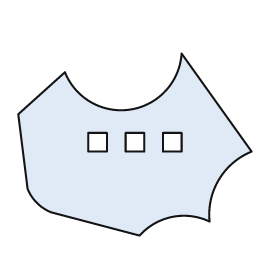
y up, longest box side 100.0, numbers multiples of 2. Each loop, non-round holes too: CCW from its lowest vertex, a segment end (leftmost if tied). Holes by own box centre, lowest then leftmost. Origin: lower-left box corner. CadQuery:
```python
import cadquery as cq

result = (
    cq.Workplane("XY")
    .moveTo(52.0, 0.0)
    .threePointArc((66.0, 8.0), (82.0, 6.0))
    .threePointArc((86.0, 24.0), (100.0, 36.0))
    .lineTo(70.0, 78.0)
    .threePointArc((48.0, 54.0), (20.0, 70.0))
    .lineTo(0.0, 52.0)
    .lineTo(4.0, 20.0)
    .threePointArc((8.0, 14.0), (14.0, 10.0))
    .close()
    .moveTo(30.0, 36.0)
    .lineTo(38.0, 36.0)
    .lineTo(38.0, 44.0)
    .lineTo(30.0, 44.0)
    .close()
    .moveTo(46.0, 36.0)
    .lineTo(54.0, 36.0)
    .lineTo(54.0, 44.0)
    .lineTo(46.0, 44.0)
    .close()
    .moveTo(62.0, 36.0)
    .lineTo(70.0, 36.0)
    .lineTo(70.0, 44.0)
    .lineTo(62.0, 44.0)
    .close()
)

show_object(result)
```